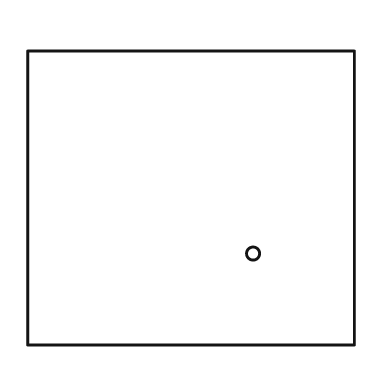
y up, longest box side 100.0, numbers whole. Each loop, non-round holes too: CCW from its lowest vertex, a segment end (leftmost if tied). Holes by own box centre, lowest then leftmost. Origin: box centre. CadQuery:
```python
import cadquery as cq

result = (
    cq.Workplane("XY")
    .moveTo(-50.0, -45.0)
    .lineTo(50.0, -45.0)
    .lineTo(50.0, 45.0)
    .lineTo(-50.0, 45.0)
    .close()
    .moveTo(19.0, -17.0)
    .circle(2.0)
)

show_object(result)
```